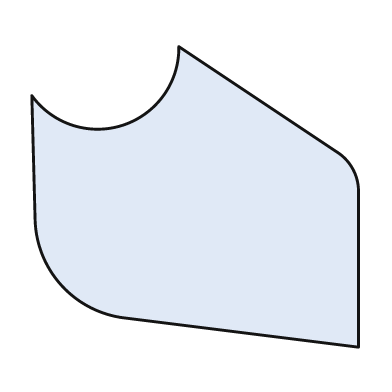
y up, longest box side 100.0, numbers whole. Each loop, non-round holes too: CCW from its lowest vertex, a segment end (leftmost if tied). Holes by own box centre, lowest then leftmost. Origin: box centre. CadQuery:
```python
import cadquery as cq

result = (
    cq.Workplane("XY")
    .moveTo(50.0, -46.0)
    .lineTo(50.0, 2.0)
    .threePointArc((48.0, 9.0), (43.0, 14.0))
    .lineTo(-5.0, 46.0)
    .threePointArc((-22.0, 22.0), (-50.0, 31.0))
    .lineTo(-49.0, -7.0)
    .threePointArc((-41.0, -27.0), (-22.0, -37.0))
    .close()
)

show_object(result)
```